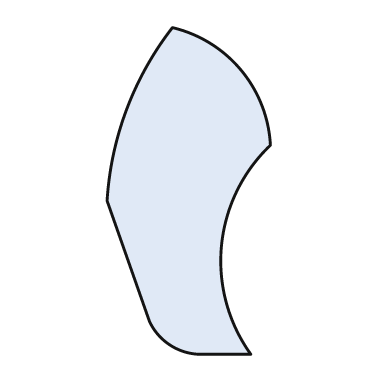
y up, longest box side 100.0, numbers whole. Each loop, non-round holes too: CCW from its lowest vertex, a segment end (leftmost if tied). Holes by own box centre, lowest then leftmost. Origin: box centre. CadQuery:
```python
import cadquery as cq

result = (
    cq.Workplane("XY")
    .moveTo(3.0, -50.0)
    .lineTo(19.0, -50.0)
    .threePointArc((10.0, -17.0), (25.0, 14.0))
    .threePointArc((16.0, 37.0), (-5.0, 50.0))
    .threePointArc((-19.0, 25.0), (-25.0, -3.0))
    .lineTo(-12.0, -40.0)
    .threePointArc((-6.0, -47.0), (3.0, -50.0))
    .close()
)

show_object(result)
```